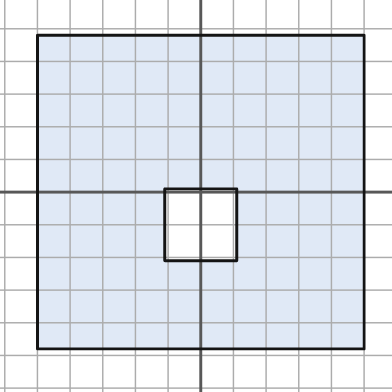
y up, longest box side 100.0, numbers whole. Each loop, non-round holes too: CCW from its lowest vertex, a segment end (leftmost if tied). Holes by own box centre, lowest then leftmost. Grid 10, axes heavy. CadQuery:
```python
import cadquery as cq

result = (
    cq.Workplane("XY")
    .moveTo(-50.0, -48.0)
    .lineTo(50.0, -48.0)
    .lineTo(50.0, 48.0)
    .lineTo(-50.0, 48.0)
    .close()
    .moveTo(-11.0, -21.0)
    .lineTo(11.0, -21.0)
    .lineTo(11.0, 1.0)
    .lineTo(-11.0, 1.0)
    .close()
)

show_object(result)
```